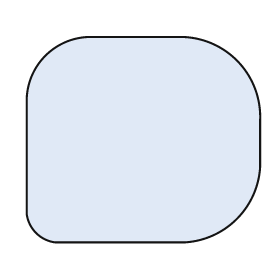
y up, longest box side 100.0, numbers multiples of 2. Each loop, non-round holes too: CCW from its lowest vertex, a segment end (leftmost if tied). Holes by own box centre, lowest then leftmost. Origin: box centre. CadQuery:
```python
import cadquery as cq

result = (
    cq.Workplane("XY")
    .moveTo(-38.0, -44.0)
    .lineTo(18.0, -44.0)
    .threePointArc((40.0, -34.0), (50.0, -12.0))
    .lineTo(50.0, 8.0)
    .threePointArc((40.0, 34.0), (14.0, 44.0))
    .lineTo(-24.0, 44.0)
    .threePointArc((-42.0, 36.0), (-50.0, 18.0))
    .lineTo(-50.0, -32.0)
    .threePointArc((-46.0, -40.0), (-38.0, -44.0))
    .close()
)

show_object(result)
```